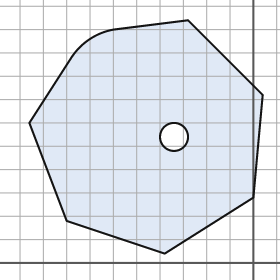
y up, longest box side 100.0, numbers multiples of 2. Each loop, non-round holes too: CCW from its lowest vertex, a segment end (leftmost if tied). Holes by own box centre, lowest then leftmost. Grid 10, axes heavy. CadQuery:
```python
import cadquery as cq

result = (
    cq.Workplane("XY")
    .moveTo(-38.0, 4.0)
    .lineTo(0.0, 28.0)
    .lineTo(4.0, 72.0)
    .lineTo(-28.0, 104.0)
    .lineTo(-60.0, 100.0)
    .threePointArc((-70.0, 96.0), (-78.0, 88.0))
    .lineTo(-96.0, 60.0)
    .lineTo(-80.0, 18.0)
    .close()
    .moveTo(-34.0, 54.0)
    .circle(6.0)
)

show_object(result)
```